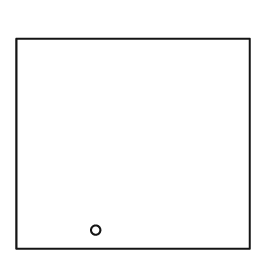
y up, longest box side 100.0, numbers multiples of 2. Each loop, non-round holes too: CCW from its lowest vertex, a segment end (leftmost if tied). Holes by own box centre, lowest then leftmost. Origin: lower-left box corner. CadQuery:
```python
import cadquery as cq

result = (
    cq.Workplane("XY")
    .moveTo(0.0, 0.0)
    .lineTo(100.0, 0.0)
    .lineTo(100.0, 90.0)
    .lineTo(0.0, 90.0)
    .close()
    .moveTo(34.0, 8.0)
    .circle(2.0)
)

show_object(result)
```